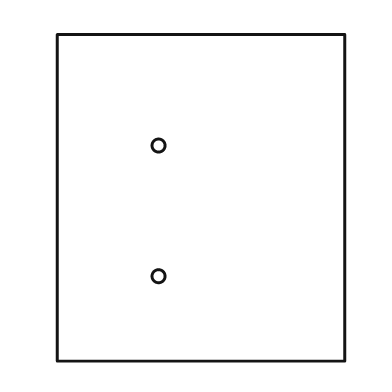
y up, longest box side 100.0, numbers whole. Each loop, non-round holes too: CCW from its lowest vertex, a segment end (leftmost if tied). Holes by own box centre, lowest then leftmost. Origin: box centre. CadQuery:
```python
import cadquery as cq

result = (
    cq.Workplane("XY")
    .moveTo(-44.0, -50.0)
    .lineTo(44.0, -50.0)
    .lineTo(44.0, 50.0)
    .lineTo(-44.0, 50.0)
    .close()
    .moveTo(-13.0, -24.0)
    .circle(2.0)
    .moveTo(-13.0, 16.0)
    .circle(2.0)
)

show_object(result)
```